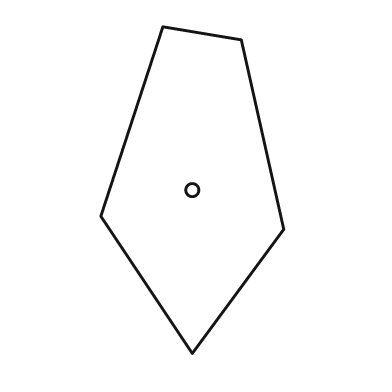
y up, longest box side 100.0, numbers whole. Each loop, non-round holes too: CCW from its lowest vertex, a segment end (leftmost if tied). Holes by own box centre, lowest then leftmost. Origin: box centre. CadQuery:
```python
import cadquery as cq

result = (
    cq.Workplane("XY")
    .moveTo(0.0, -50.0)
    .lineTo(28.0, -12.0)
    .lineTo(15.0, 46.0)
    .lineTo(-9.0, 50.0)
    .lineTo(-28.0, -8.0)
    .close()
    .moveTo(0.0, 0.0)
    .circle(2.0)
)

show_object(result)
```